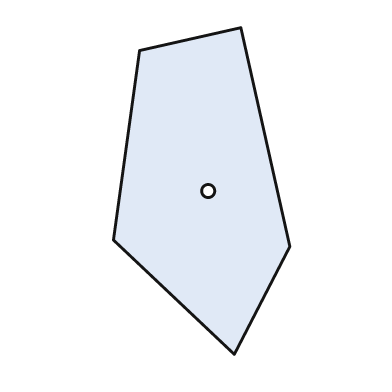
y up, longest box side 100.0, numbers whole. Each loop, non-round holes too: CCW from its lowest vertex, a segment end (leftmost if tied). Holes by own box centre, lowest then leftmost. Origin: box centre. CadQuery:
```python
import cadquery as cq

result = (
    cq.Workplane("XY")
    .moveTo(10.0, -50.0)
    .lineTo(27.0, -17.0)
    .lineTo(12.0, 50.0)
    .lineTo(-19.0, 43.0)
    .lineTo(-27.0, -15.0)
    .close()
    .moveTo(2.0, 0.0)
    .circle(2.0)
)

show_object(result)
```